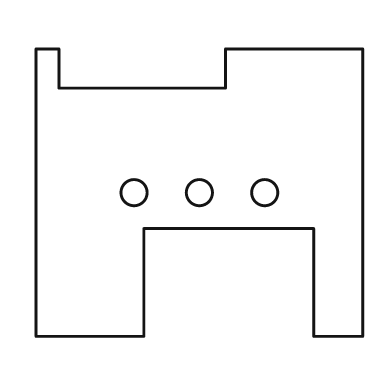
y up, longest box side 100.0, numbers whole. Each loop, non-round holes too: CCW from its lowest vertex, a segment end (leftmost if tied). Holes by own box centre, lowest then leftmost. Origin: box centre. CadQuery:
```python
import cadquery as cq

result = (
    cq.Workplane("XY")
    .moveTo(-50.0, -44.0)
    .lineTo(-17.0, -44.0)
    .lineTo(-17.0, -11.0)
    .lineTo(35.0, -11.0)
    .lineTo(35.0, -44.0)
    .lineTo(50.0, -44.0)
    .lineTo(50.0, 44.0)
    .lineTo(8.0, 44.0)
    .lineTo(8.0, 32.0)
    .lineTo(-43.0, 32.0)
    .lineTo(-43.0, 44.0)
    .lineTo(-50.0, 44.0)
    .close()
    .moveTo(-20.0, 0.0)
    .circle(4.0)
    .moveTo(0.0, 0.0)
    .circle(4.0)
    .moveTo(20.0, 0.0)
    .circle(4.0)
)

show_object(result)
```